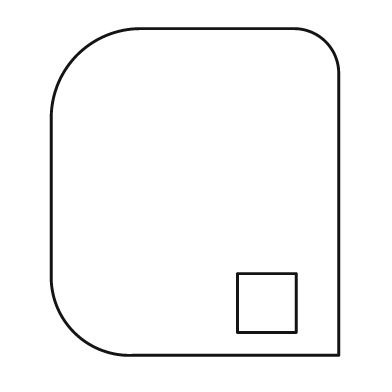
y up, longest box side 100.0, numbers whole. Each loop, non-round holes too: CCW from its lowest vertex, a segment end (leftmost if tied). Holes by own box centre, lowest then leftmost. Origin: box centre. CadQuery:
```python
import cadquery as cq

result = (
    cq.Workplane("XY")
    .moveTo(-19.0, -50.0)
    .lineTo(44.0, -50.0)
    .lineTo(44.0, 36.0)
    .threePointArc((40.0, 46.0), (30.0, 50.0))
    .lineTo(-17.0, 50.0)
    .threePointArc((-36.0, 42.0), (-44.0, 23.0))
    .lineTo(-44.0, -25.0)
    .threePointArc((-37.0, -43.0), (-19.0, -50.0))
    .close()
    .moveTo(13.0, -43.0)
    .lineTo(31.0, -43.0)
    .lineTo(31.0, -25.0)
    .lineTo(13.0, -25.0)
    .close()
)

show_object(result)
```